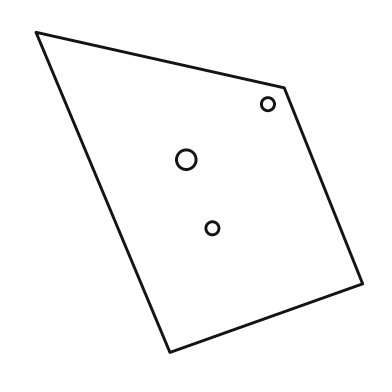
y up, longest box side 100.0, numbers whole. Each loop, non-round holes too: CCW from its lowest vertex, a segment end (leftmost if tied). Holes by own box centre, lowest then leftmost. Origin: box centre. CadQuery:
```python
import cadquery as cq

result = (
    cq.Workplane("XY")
    .moveTo(-9.0, -49.0)
    .lineTo(50.0, -28.0)
    .lineTo(26.0, 32.0)
    .lineTo(-50.0, 49.0)
    .close()
    .moveTo(4.0, -11.0)
    .circle(2.0)
    .moveTo(-4.0, 10.0)
    .circle(3.0)
    .moveTo(21.0, 27.0)
    .circle(2.0)
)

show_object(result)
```